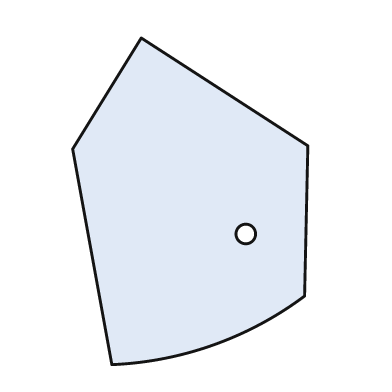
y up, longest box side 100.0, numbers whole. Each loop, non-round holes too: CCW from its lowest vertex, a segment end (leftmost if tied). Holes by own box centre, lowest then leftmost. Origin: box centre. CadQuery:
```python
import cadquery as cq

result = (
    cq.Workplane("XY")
    .moveTo(-24.0, -50.0)
    .threePointArc((7.0, -44.0), (35.0, -29.0))
    .lineTo(36.0, 17.0)
    .lineTo(-15.0, 50.0)
    .lineTo(-36.0, 16.0)
    .close()
    .moveTo(17.0, -10.0)
    .circle(3.0)
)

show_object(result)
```